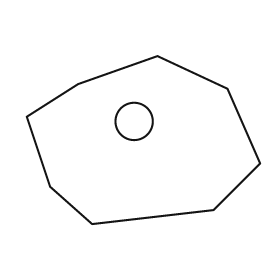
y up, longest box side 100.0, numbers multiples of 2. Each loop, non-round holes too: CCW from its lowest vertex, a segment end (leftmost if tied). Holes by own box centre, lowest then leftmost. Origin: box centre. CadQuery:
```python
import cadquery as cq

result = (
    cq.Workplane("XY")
    .moveTo(-22.0, -36.0)
    .lineTo(30.0, -30.0)
    .lineTo(50.0, -10.0)
    .lineTo(36.0, 22.0)
    .lineTo(6.0, 36.0)
    .lineTo(-28.0, 24.0)
    .lineTo(-50.0, 10.0)
    .lineTo(-40.0, -20.0)
    .close()
    .moveTo(-4.0, 8.0)
    .circle(8.0)
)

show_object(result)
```